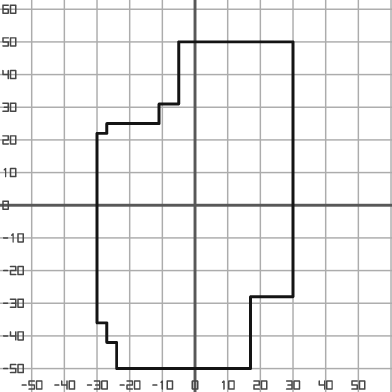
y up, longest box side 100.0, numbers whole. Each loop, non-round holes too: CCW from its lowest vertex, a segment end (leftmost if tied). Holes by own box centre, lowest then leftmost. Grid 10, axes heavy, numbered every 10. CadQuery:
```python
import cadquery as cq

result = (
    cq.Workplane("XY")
    .moveTo(-24.0, -50.0)
    .lineTo(17.0, -50.0)
    .lineTo(17.0, -28.0)
    .lineTo(30.0, -28.0)
    .lineTo(30.0, 50.0)
    .lineTo(-5.0, 50.0)
    .lineTo(-5.0, 31.0)
    .lineTo(-11.0, 31.0)
    .lineTo(-11.0, 25.0)
    .lineTo(-27.0, 25.0)
    .lineTo(-27.0, 22.0)
    .lineTo(-30.0, 22.0)
    .lineTo(-30.0, -36.0)
    .lineTo(-27.0, -36.0)
    .lineTo(-27.0, -42.0)
    .lineTo(-24.0, -42.0)
    .close()
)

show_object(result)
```